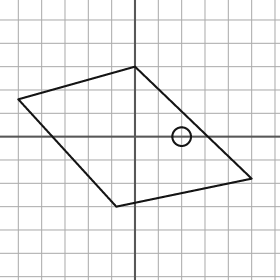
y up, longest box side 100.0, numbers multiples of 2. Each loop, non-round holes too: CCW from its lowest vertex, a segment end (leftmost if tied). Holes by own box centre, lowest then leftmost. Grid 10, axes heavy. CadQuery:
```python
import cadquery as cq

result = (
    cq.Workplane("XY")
    .moveTo(-8.0, -30.0)
    .lineTo(50.0, -18.0)
    .lineTo(0.0, 30.0)
    .lineTo(-50.0, 16.0)
    .close()
    .moveTo(20.0, 0.0)
    .circle(4.0)
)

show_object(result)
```